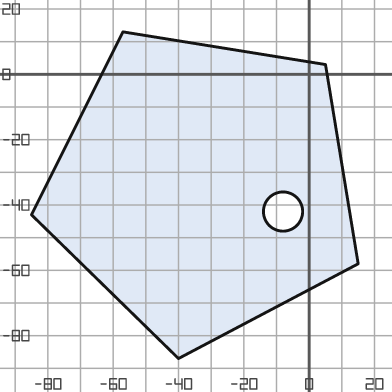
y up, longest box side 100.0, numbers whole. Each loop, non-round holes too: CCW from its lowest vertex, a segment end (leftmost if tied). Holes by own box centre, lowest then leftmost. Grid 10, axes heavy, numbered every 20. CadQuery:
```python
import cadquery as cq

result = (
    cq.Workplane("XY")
    .moveTo(-40.0, -87.0)
    .lineTo(15.0, -58.0)
    .lineTo(5.0, 3.0)
    .lineTo(-57.0, 13.0)
    .lineTo(-85.0, -43.0)
    .close()
    .moveTo(-8.0, -42.0)
    .circle(6.0)
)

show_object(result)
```